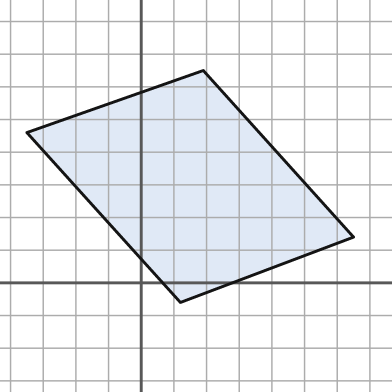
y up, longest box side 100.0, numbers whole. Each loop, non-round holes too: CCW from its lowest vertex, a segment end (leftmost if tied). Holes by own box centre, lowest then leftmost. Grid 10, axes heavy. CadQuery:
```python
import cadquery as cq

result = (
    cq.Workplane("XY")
    .moveTo(12.0, -6.0)
    .lineTo(65.0, 14.0)
    .lineTo(19.0, 65.0)
    .lineTo(-35.0, 46.0)
    .close()
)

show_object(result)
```